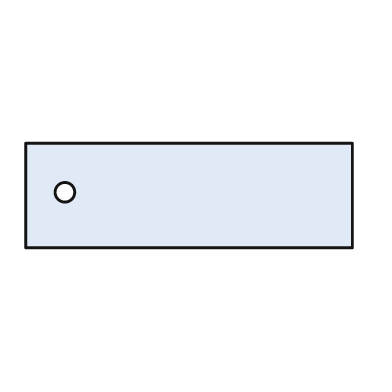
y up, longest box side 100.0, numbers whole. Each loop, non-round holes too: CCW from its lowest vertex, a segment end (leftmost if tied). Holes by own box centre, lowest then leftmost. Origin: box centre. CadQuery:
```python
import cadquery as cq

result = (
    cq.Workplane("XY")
    .moveTo(-50.0, -16.0)
    .lineTo(50.0, -16.0)
    .lineTo(50.0, 16.0)
    .lineTo(-50.0, 16.0)
    .close()
    .moveTo(-38.0, 1.0)
    .circle(3.0)
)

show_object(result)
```